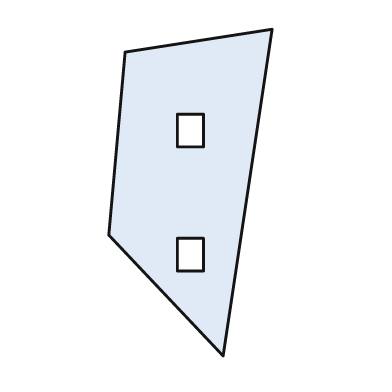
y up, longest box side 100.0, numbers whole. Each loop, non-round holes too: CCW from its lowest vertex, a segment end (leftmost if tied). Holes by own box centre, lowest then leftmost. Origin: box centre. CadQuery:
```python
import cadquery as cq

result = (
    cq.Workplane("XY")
    .moveTo(10.0, -50.0)
    .lineTo(25.0, 50.0)
    .lineTo(-20.0, 43.0)
    .lineTo(-25.0, -13.0)
    .close()
    .moveTo(-4.0, -24.0)
    .lineTo(4.0, -24.0)
    .lineTo(4.0, -14.0)
    .lineTo(-4.0, -14.0)
    .close()
    .moveTo(-4.0, 14.0)
    .lineTo(4.0, 14.0)
    .lineTo(4.0, 24.0)
    .lineTo(-4.0, 24.0)
    .close()
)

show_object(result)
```